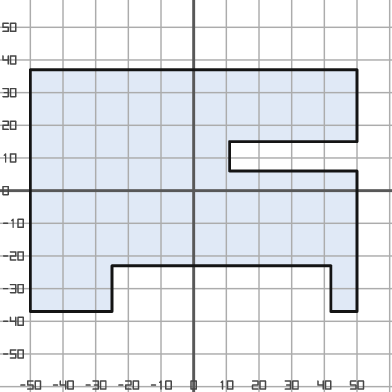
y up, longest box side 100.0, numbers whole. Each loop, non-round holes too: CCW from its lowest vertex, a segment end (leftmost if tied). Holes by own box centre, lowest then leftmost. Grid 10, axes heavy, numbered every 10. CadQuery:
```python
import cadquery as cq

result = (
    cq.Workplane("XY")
    .moveTo(-50.0, -37.0)
    .lineTo(-25.0, -37.0)
    .lineTo(-25.0, -23.0)
    .lineTo(42.0, -23.0)
    .lineTo(42.0, -37.0)
    .lineTo(50.0, -37.0)
    .lineTo(50.0, 6.0)
    .lineTo(11.0, 6.0)
    .lineTo(11.0, 15.0)
    .lineTo(50.0, 15.0)
    .lineTo(50.0, 37.0)
    .lineTo(-50.0, 37.0)
    .close()
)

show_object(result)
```